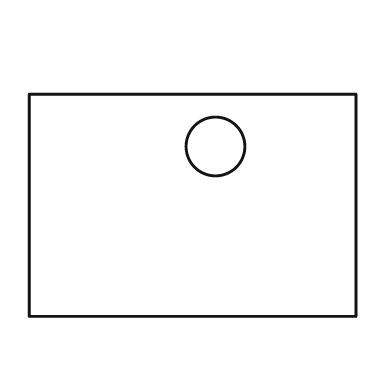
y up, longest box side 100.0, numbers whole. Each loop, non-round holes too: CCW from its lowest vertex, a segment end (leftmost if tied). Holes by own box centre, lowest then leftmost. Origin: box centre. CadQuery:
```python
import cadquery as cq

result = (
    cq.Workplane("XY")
    .moveTo(-50.0, -34.0)
    .lineTo(50.0, -34.0)
    .lineTo(50.0, 34.0)
    .lineTo(-50.0, 34.0)
    .close()
    .moveTo(7.0, 18.0)
    .circle(9.0)
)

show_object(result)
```